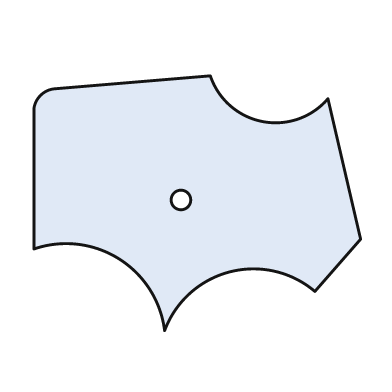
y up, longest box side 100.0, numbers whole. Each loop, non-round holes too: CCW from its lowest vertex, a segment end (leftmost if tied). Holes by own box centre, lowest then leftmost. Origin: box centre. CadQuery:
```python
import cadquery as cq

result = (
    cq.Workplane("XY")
    .moveTo(-10.0, -39.0)
    .threePointArc((10.0, -21.0), (36.0, -27.0))
    .lineTo(50.0, -11.0)
    .lineTo(40.0, 32.0)
    .threePointArc((20.0, 25.0), (4.0, 39.0))
    .lineTo(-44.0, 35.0)
    .threePointArc((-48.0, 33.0), (-50.0, 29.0))
    .lineTo(-50.0, -14.0)
    .threePointArc((-24.0, -17.0), (-10.0, -39.0))
    .close()
    .moveTo(-5.0, 1.0)
    .circle(3.0)
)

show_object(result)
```